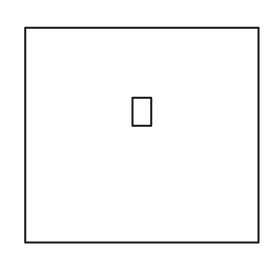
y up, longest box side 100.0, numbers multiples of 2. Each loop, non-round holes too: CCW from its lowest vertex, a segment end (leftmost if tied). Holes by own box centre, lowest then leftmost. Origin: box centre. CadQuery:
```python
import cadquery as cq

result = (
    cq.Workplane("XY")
    .moveTo(-50.0, -46.0)
    .lineTo(50.0, -46.0)
    .lineTo(50.0, 46.0)
    .lineTo(-50.0, 46.0)
    .close()
    .moveTo(-4.0, 4.0)
    .lineTo(4.0, 4.0)
    .lineTo(4.0, 16.0)
    .lineTo(-4.0, 16.0)
    .close()
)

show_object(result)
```